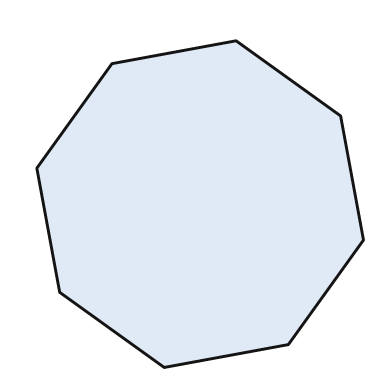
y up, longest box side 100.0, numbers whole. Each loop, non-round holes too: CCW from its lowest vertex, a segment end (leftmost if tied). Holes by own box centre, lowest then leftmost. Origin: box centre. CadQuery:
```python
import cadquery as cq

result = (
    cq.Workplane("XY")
    .moveTo(-11.0, -50.0)
    .lineTo(27.0, -43.0)
    .lineTo(50.0, -11.0)
    .lineTo(43.0, 27.0)
    .lineTo(11.0, 50.0)
    .lineTo(-27.0, 43.0)
    .lineTo(-50.0, 11.0)
    .lineTo(-43.0, -27.0)
    .close()
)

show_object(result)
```